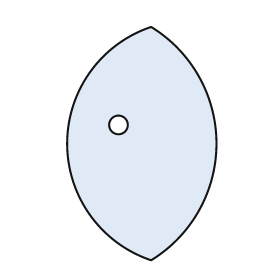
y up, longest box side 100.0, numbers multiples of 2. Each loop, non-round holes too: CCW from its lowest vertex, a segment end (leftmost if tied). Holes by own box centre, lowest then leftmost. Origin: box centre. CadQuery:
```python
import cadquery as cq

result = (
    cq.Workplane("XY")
    .moveTo(4.0, -50.0)
    .threePointArc((32.0, 0.0), (4.0, 50.0))
    .threePointArc((-32.0, 0.0), (4.0, -50.0))
    .close()
    .moveTo(-10.0, 8.0)
    .circle(4.0)
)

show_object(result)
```